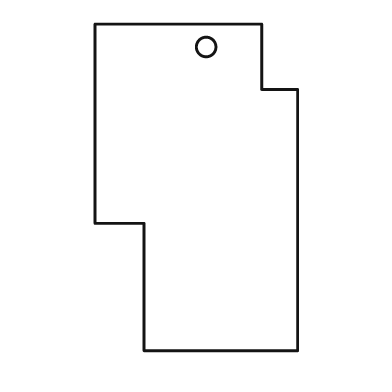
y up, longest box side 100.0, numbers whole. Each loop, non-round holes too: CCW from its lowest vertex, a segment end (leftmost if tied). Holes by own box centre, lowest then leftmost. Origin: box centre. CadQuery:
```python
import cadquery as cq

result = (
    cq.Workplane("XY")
    .moveTo(-16.0, -50.0)
    .lineTo(31.0, -50.0)
    .lineTo(31.0, 30.0)
    .lineTo(20.0, 30.0)
    .lineTo(20.0, 50.0)
    .lineTo(-31.0, 50.0)
    .lineTo(-31.0, -11.0)
    .lineTo(-16.0, -11.0)
    .close()
    .moveTo(3.0, 43.0)
    .circle(3.0)
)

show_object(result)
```